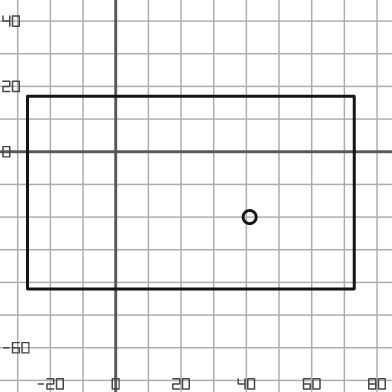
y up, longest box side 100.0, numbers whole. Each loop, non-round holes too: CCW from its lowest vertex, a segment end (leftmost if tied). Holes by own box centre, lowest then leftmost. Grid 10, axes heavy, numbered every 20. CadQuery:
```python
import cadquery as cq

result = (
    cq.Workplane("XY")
    .moveTo(-27.0, -42.0)
    .lineTo(73.0, -42.0)
    .lineTo(73.0, 17.0)
    .lineTo(-27.0, 17.0)
    .close()
    .moveTo(41.0, -20.0)
    .circle(2.0)
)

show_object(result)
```